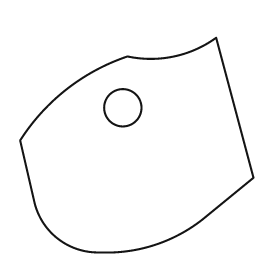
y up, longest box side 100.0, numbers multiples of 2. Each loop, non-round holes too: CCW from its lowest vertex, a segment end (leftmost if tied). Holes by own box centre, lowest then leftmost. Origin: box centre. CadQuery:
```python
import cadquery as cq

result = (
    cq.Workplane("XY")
    .moveTo(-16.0, -46.0)
    .lineTo(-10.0, -46.0)
    .threePointArc((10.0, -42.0), (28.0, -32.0))
    .lineTo(50.0, -14.0)
    .lineTo(34.0, 46.0)
    .threePointArc((16.0, 38.0), (-4.0, 38.0))
    .threePointArc((-30.0, 24.0), (-50.0, 2.0))
    .lineTo(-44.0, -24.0)
    .threePointArc((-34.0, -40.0), (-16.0, -46.0))
    .close()
    .moveTo(-6.0, 16.0)
    .circle(8.0)
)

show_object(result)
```